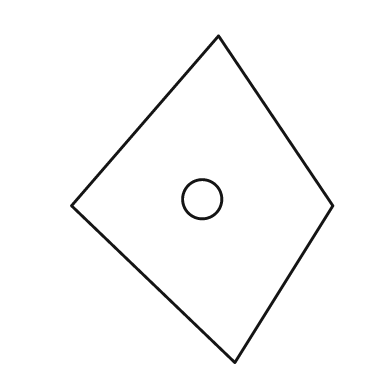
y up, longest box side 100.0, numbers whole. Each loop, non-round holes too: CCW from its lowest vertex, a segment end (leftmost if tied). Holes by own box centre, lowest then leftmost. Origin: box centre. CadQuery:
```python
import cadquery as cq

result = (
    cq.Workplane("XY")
    .moveTo(10.0, -50.0)
    .lineTo(40.0, -2.0)
    .lineTo(5.0, 50.0)
    .lineTo(-40.0, -2.0)
    .close()
    .moveTo(0.0, 0.0)
    .circle(6.0)
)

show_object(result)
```